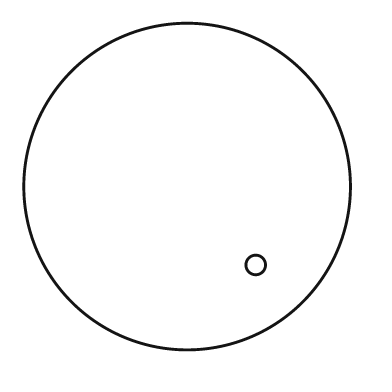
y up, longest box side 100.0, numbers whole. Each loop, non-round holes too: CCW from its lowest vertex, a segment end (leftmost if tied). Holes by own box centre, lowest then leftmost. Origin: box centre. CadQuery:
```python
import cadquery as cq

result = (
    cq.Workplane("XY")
    .moveTo(0.0, 0.0)
    .circle(50.0)
    .moveTo(21.0, -24.0)
    .circle(3.0)
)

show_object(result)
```